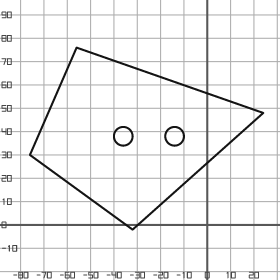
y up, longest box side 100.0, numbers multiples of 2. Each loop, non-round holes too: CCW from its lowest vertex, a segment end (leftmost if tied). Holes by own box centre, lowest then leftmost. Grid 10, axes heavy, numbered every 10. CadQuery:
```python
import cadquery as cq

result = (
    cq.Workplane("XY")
    .moveTo(-32.0, -2.0)
    .lineTo(24.0, 48.0)
    .lineTo(-56.0, 76.0)
    .lineTo(-76.0, 30.0)
    .close()
    .moveTo(-36.0, 38.0)
    .circle(4.0)
    .moveTo(-14.0, 38.0)
    .circle(4.0)
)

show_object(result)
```